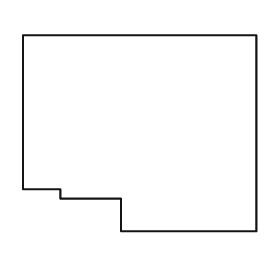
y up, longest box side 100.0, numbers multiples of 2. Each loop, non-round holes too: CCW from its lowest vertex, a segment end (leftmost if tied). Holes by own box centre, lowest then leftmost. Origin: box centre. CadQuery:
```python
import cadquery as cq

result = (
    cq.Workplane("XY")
    .moveTo(-8.0, -42.0)
    .lineTo(50.0, -42.0)
    .lineTo(50.0, 42.0)
    .lineTo(-50.0, 42.0)
    .lineTo(-50.0, -24.0)
    .lineTo(-34.0, -24.0)
    .lineTo(-34.0, -28.0)
    .lineTo(-8.0, -28.0)
    .close()
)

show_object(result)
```